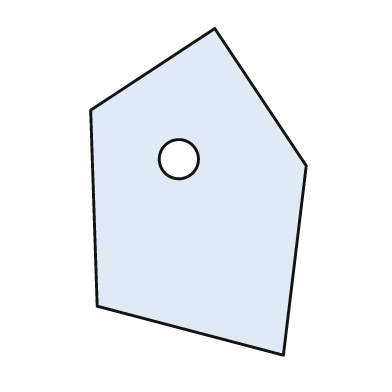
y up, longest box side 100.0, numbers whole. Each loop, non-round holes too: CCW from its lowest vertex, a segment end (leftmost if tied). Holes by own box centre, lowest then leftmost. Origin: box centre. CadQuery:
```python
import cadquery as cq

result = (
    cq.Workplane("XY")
    .moveTo(26.0, -50.0)
    .lineTo(33.0, 8.0)
    .lineTo(5.0, 50.0)
    .lineTo(-33.0, 25.0)
    .lineTo(-31.0, -35.0)
    .close()
    .moveTo(-6.0, 10.0)
    .circle(6.0)
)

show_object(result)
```